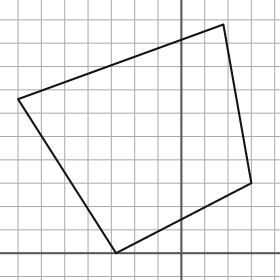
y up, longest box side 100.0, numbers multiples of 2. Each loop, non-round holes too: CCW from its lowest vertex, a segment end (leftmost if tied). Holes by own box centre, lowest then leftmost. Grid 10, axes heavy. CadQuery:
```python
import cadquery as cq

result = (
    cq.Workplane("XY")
    .moveTo(-28.0, 0.0)
    .lineTo(30.0, 30.0)
    .lineTo(18.0, 98.0)
    .lineTo(-70.0, 66.0)
    .close()
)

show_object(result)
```